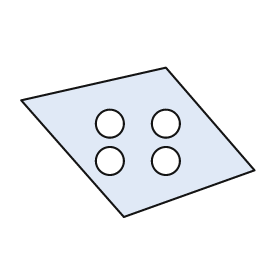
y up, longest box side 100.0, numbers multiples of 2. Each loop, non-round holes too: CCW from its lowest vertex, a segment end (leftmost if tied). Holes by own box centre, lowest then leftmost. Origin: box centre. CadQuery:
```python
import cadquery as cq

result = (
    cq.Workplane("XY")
    .moveTo(-6.0, -32.0)
    .lineTo(50.0, -12.0)
    .lineTo(12.0, 32.0)
    .lineTo(-50.0, 18.0)
    .close()
    .moveTo(-12.0, -8.0)
    .circle(6.0)
    .moveTo(12.0, -8.0)
    .circle(6.0)
    .moveTo(-12.0, 8.0)
    .circle(6.0)
    .moveTo(12.0, 8.0)
    .circle(6.0)
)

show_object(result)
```